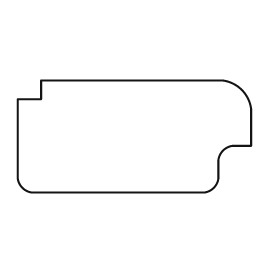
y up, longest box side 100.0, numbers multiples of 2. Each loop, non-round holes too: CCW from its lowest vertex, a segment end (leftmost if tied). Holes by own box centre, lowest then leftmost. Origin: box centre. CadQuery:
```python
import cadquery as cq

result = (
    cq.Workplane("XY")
    .moveTo(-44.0, -24.0)
    .lineTo(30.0, -24.0)
    .threePointArc((34.0, -22.0), (36.0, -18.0))
    .lineTo(36.0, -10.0)
    .threePointArc((38.0, -6.0), (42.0, -4.0))
    .lineTo(50.0, -4.0)
    .lineTo(50.0, 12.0)
    .threePointArc((46.0, 20.0), (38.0, 24.0))
    .lineTo(-40.0, 24.0)
    .lineTo(-40.0, 16.0)
    .lineTo(-50.0, 16.0)
    .lineTo(-50.0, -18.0)
    .threePointArc((-48.0, -22.0), (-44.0, -24.0))
    .close()
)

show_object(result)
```